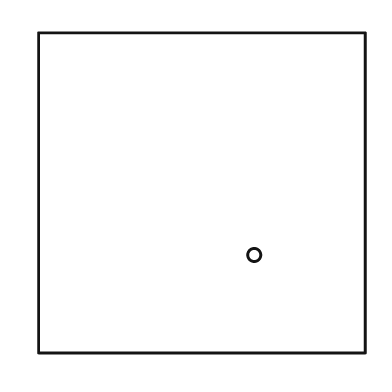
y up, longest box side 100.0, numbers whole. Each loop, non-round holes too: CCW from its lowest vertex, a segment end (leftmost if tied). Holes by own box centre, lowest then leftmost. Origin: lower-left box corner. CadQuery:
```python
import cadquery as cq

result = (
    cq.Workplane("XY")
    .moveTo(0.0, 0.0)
    .lineTo(100.0, 0.0)
    .lineTo(100.0, 98.0)
    .lineTo(0.0, 98.0)
    .close()
    .moveTo(66.0, 30.0)
    .circle(2.0)
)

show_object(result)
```